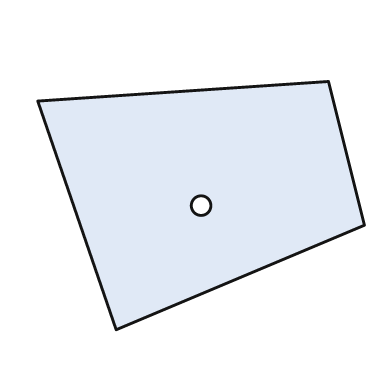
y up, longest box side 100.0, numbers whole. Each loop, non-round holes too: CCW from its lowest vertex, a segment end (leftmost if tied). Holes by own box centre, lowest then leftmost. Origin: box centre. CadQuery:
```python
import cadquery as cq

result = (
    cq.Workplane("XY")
    .moveTo(-26.0, -38.0)
    .lineTo(50.0, -6.0)
    .lineTo(39.0, 38.0)
    .lineTo(-50.0, 32.0)
    .close()
    .moveTo(0.0, 0.0)
    .circle(3.0)
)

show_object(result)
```